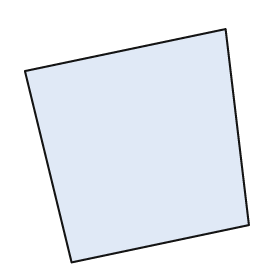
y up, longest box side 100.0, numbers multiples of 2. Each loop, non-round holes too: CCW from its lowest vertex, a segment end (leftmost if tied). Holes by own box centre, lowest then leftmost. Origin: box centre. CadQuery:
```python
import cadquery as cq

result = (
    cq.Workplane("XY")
    .moveTo(-28.0, -50.0)
    .lineTo(48.0, -34.0)
    .lineTo(38.0, 50.0)
    .lineTo(-48.0, 32.0)
    .close()
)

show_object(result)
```